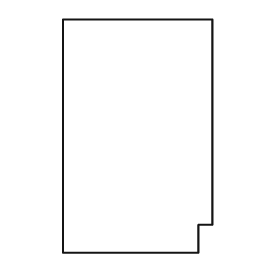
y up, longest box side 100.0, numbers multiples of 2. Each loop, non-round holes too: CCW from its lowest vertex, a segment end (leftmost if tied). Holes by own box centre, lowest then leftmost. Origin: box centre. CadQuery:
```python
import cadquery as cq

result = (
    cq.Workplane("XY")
    .moveTo(-32.0, -50.0)
    .lineTo(26.0, -50.0)
    .lineTo(26.0, -38.0)
    .lineTo(32.0, -38.0)
    .lineTo(32.0, 50.0)
    .lineTo(-32.0, 50.0)
    .close()
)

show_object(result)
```